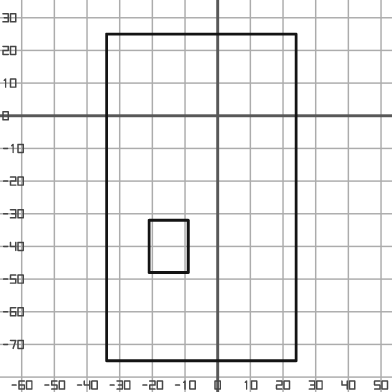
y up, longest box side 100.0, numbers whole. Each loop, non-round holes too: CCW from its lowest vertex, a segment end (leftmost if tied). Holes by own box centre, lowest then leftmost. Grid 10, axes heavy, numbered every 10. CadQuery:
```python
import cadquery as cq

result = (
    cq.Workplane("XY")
    .moveTo(-34.0, -75.0)
    .lineTo(24.0, -75.0)
    .lineTo(24.0, 25.0)
    .lineTo(-34.0, 25.0)
    .close()
    .moveTo(-21.0, -48.0)
    .lineTo(-9.0, -48.0)
    .lineTo(-9.0, -32.0)
    .lineTo(-21.0, -32.0)
    .close()
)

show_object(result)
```